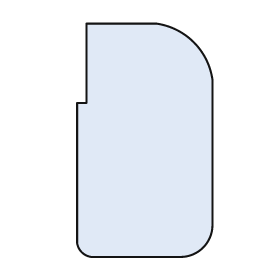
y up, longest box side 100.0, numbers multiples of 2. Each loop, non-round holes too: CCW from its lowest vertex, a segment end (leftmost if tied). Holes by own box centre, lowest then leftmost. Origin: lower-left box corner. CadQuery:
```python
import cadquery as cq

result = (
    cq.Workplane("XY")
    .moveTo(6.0, 0.0)
    .lineTo(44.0, 0.0)
    .threePointArc((54.0, 4.0), (58.0, 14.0))
    .lineTo(58.0, 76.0)
    .threePointArc((50.0, 92.0), (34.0, 100.0))
    .lineTo(4.0, 100.0)
    .lineTo(4.0, 66.0)
    .lineTo(0.0, 66.0)
    .lineTo(0.0, 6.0)
    .threePointArc((2.0, 2.0), (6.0, 0.0))
    .close()
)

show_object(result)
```